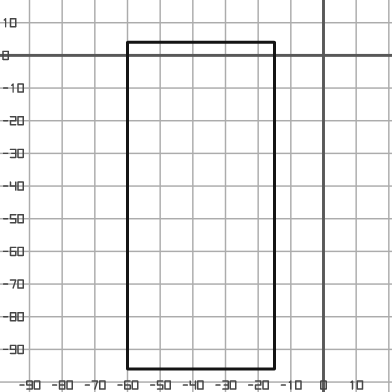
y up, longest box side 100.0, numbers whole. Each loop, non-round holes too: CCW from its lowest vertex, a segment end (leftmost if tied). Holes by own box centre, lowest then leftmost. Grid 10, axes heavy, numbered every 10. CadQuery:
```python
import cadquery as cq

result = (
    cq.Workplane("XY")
    .moveTo(-60.0, -96.0)
    .lineTo(-15.0, -96.0)
    .lineTo(-15.0, 4.0)
    .lineTo(-60.0, 4.0)
    .close()
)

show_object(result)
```